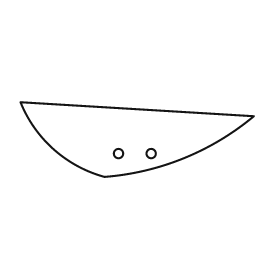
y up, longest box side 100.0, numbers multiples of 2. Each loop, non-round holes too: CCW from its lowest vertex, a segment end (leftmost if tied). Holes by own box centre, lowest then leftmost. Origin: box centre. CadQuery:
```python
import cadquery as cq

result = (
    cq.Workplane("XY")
    .moveTo(-14.0, -16.0)
    .threePointArc((20.0, -8.0), (50.0, 10.0))
    .lineTo(-50.0, 16.0)
    .threePointArc((-36.0, -4.0), (-14.0, -16.0))
    .close()
    .moveTo(-8.0, -6.0)
    .circle(2.0)
    .moveTo(6.0, -6.0)
    .circle(2.0)
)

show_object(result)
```